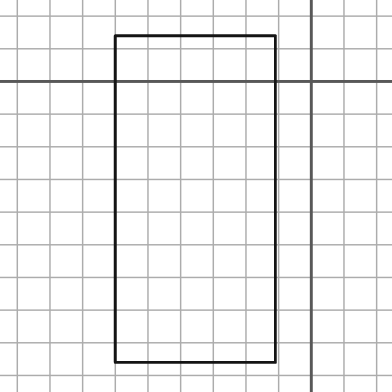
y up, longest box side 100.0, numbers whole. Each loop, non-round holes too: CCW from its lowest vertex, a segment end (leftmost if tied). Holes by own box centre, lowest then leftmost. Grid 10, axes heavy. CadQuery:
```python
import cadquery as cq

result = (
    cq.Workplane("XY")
    .moveTo(-60.0, -86.0)
    .lineTo(-11.0, -86.0)
    .lineTo(-11.0, 14.0)
    .lineTo(-60.0, 14.0)
    .close()
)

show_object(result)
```